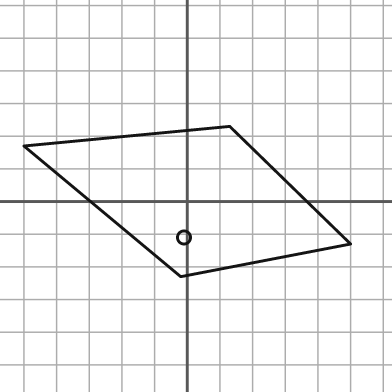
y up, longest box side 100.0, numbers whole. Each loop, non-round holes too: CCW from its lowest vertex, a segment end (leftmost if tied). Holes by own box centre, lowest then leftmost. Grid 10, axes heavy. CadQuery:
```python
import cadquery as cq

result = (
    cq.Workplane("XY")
    .moveTo(-2.0, -23.0)
    .lineTo(50.0, -13.0)
    .lineTo(13.0, 23.0)
    .lineTo(-50.0, 17.0)
    .close()
    .moveTo(-1.0, -11.0)
    .circle(2.0)
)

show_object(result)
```